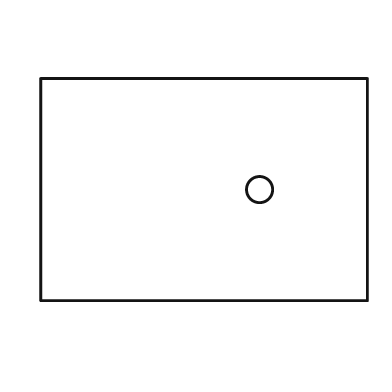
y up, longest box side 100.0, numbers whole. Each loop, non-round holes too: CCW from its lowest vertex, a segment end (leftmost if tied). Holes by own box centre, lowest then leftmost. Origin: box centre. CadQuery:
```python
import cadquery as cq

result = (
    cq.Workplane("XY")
    .moveTo(-50.0, -34.0)
    .lineTo(50.0, -34.0)
    .lineTo(50.0, 34.0)
    .lineTo(-50.0, 34.0)
    .close()
    .moveTo(17.0, 0.0)
    .circle(4.0)
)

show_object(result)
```